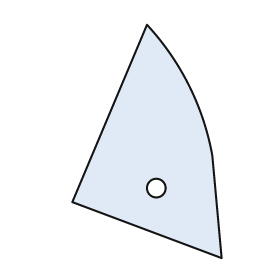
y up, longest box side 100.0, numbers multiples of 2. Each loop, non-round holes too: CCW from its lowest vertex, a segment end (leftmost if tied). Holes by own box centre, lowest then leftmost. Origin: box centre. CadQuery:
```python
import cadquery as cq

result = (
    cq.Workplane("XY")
    .moveTo(32.0, -50.0)
    .lineTo(28.0, -6.0)
    .threePointArc((18.0, 24.0), (0.0, 50.0))
    .lineTo(-32.0, -26.0)
    .close()
    .moveTo(4.0, -20.0)
    .circle(4.0)
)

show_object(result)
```